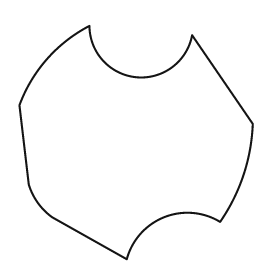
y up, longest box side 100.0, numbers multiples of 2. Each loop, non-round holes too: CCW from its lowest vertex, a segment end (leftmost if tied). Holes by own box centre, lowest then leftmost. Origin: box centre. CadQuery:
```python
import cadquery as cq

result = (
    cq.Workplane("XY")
    .moveTo(-4.0, -50.0)
    .threePointArc((12.0, -32.0), (36.0, -34.0))
    .threePointArc((46.0, -14.0), (50.0, 8.0))
    .lineTo(24.0, 46.0)
    .threePointArc((0.0, 28.0), (-20.0, 50.0))
    .threePointArc((-38.0, 36.0), (-50.0, 16.0))
    .lineTo(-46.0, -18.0)
    .threePointArc((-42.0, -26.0), (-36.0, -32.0))
    .close()
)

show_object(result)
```